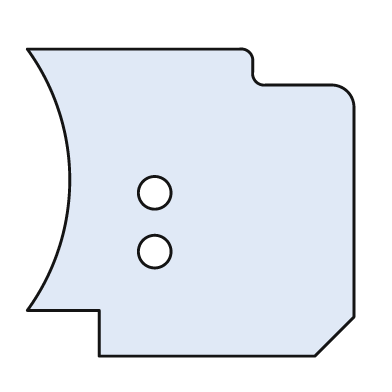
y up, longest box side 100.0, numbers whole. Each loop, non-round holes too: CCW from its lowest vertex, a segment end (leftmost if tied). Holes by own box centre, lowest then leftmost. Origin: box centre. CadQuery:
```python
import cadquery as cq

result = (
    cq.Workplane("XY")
    .moveTo(-28.0, -47.0)
    .lineTo(38.0, -47.0)
    .lineTo(50.0, -35.0)
    .lineTo(50.0, 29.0)
    .threePointArc((48.0, 34.0), (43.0, 36.0))
    .lineTo(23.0, 36.0)
    .threePointArc((20.0, 37.0), (19.0, 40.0))
    .lineTo(19.0, 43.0)
    .threePointArc((18.0, 46.0), (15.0, 47.0))
    .lineTo(-50.0, 47.0)
    .threePointArc((-37.0, 7.0), (-50.0, -33.0))
    .lineTo(-28.0, -33.0)
    .close()
    .moveTo(-11.0, -15.0)
    .circle(5.0)
    .moveTo(-11.0, 3.0)
    .circle(5.0)
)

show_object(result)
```